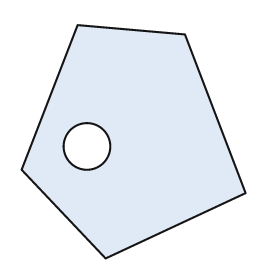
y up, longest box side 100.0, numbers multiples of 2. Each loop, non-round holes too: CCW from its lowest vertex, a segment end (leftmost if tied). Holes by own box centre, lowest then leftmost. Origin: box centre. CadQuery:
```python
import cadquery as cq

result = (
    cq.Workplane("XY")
    .moveTo(-12.0, -50.0)
    .lineTo(48.0, -22.0)
    .lineTo(22.0, 46.0)
    .lineTo(-24.0, 50.0)
    .lineTo(-48.0, -12.0)
    .close()
    .moveTo(-20.0, -2.0)
    .circle(10.0)
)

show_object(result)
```